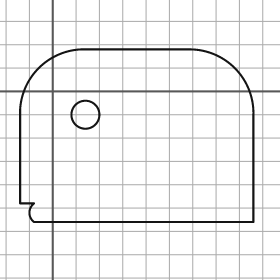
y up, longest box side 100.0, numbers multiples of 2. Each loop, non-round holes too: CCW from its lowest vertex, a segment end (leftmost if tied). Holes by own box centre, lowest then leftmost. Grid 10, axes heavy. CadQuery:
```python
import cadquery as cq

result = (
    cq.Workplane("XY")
    .moveTo(-8.0, -56.0)
    .lineTo(86.0, -56.0)
    .lineTo(86.0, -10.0)
    .threePointArc((78.0, 10.0), (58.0, 18.0))
    .lineTo(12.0, 18.0)
    .threePointArc((-6.0, 10.0), (-14.0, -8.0))
    .lineTo(-14.0, -48.0)
    .lineTo(-8.0, -48.0)
    .threePointArc((-10.0, -52.0), (-8.0, -56.0))
    .close()
    .moveTo(14.0, -10.0)
    .circle(6.0)
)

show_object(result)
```